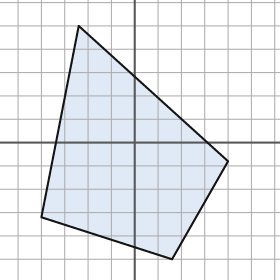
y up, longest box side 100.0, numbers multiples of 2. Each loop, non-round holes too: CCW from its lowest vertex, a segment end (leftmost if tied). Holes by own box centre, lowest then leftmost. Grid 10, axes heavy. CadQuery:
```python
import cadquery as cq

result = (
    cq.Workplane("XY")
    .moveTo(16.0, -50.0)
    .lineTo(40.0, -8.0)
    .lineTo(-24.0, 50.0)
    .lineTo(-40.0, -32.0)
    .close()
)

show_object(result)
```